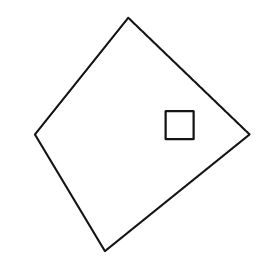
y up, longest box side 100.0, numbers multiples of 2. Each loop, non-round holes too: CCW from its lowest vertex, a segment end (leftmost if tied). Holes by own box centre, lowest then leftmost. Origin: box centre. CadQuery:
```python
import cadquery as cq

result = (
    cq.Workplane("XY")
    .moveTo(-16.0, -50.0)
    .lineTo(46.0, 0.0)
    .lineTo(-6.0, 50.0)
    .lineTo(-46.0, 0.0)
    .close()
    .moveTo(10.0, -2.0)
    .lineTo(22.0, -2.0)
    .lineTo(22.0, 10.0)
    .lineTo(10.0, 10.0)
    .close()
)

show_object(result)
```